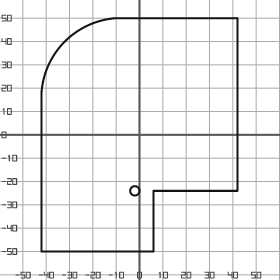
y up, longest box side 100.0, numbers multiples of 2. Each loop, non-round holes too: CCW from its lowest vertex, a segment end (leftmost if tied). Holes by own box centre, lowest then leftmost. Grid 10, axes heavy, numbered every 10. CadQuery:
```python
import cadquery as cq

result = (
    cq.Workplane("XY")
    .moveTo(-42.0, -50.0)
    .lineTo(6.0, -50.0)
    .lineTo(6.0, -24.0)
    .lineTo(42.0, -24.0)
    .lineTo(42.0, 50.0)
    .lineTo(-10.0, 50.0)
    .threePointArc((-32.0, 40.0), (-42.0, 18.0))
    .close()
    .moveTo(-2.0, -24.0)
    .circle(2.0)
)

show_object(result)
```